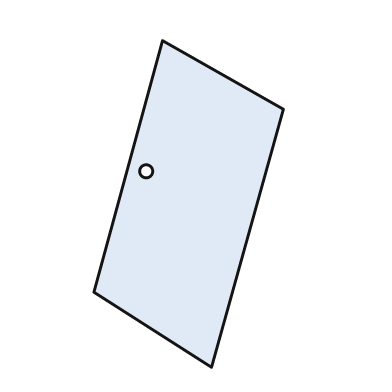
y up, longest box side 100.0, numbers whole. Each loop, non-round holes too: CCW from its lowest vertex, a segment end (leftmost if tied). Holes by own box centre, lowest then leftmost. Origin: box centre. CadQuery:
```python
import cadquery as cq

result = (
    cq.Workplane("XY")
    .moveTo(7.0, -50.0)
    .lineTo(29.0, 29.0)
    .lineTo(-8.0, 50.0)
    .lineTo(-29.0, -27.0)
    .close()
    .moveTo(-13.0, 10.0)
    .circle(2.0)
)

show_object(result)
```